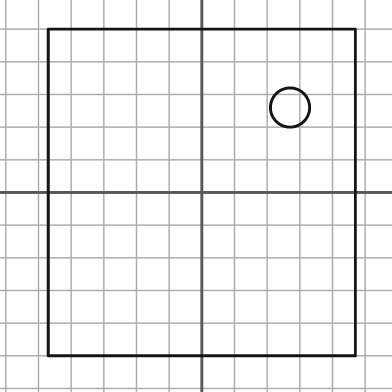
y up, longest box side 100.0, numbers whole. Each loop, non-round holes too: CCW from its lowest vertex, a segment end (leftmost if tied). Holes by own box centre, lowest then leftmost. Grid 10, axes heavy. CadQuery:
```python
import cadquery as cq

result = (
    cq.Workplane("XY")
    .moveTo(-47.0, -50.0)
    .lineTo(47.0, -50.0)
    .lineTo(47.0, 50.0)
    .lineTo(-47.0, 50.0)
    .close()
    .moveTo(27.0, 26.0)
    .circle(6.0)
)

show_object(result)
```